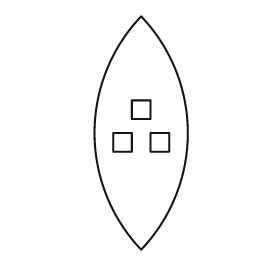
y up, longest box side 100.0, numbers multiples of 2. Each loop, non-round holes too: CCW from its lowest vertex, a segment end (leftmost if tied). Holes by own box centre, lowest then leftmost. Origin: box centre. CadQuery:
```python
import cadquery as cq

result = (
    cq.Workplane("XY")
    .moveTo(0.0, -50.0)
    .threePointArc((20.0, 0.0), (0.0, 50.0))
    .threePointArc((-20.0, 0.0), (0.0, -50.0))
    .close()
    .moveTo(-12.0, -8.0)
    .lineTo(-4.0, -8.0)
    .lineTo(-4.0, 0.0)
    .lineTo(-12.0, 0.0)
    .close()
    .moveTo(4.0, -8.0)
    .lineTo(12.0, -8.0)
    .lineTo(12.0, 0.0)
    .lineTo(4.0, 0.0)
    .close()
    .moveTo(-4.0, 6.0)
    .lineTo(4.0, 6.0)
    .lineTo(4.0, 14.0)
    .lineTo(-4.0, 14.0)
    .close()
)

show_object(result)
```